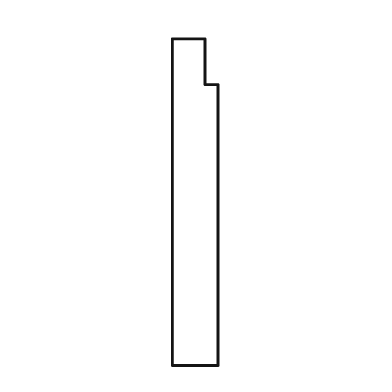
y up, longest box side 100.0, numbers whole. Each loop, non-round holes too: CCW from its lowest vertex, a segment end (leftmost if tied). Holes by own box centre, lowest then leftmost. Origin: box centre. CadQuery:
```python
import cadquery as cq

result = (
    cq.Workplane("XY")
    .moveTo(-7.0, -50.0)
    .lineTo(7.0, -50.0)
    .lineTo(7.0, 36.0)
    .lineTo(3.0, 36.0)
    .lineTo(3.0, 50.0)
    .lineTo(-7.0, 50.0)
    .close()
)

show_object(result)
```